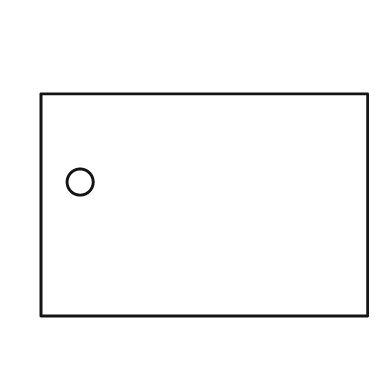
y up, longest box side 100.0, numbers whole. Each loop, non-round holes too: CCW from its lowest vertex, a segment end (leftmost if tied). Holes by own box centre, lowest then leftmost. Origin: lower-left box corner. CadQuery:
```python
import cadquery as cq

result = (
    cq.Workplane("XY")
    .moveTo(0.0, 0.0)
    .lineTo(100.0, 0.0)
    .lineTo(100.0, 68.0)
    .lineTo(0.0, 68.0)
    .close()
    .moveTo(12.0, 41.0)
    .circle(4.0)
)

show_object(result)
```